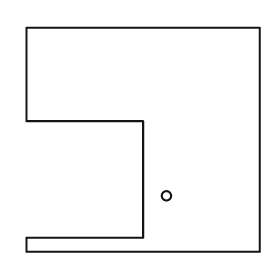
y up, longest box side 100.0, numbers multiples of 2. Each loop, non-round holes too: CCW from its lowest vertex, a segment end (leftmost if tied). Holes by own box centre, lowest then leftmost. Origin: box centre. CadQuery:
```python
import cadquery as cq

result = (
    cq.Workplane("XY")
    .moveTo(-50.0, -48.0)
    .lineTo(50.0, -48.0)
    .lineTo(50.0, 48.0)
    .lineTo(-50.0, 48.0)
    .lineTo(-50.0, 8.0)
    .lineTo(0.0, 8.0)
    .lineTo(0.0, -42.0)
    .lineTo(-50.0, -42.0)
    .close()
    .moveTo(10.0, -24.0)
    .circle(2.0)
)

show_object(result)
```